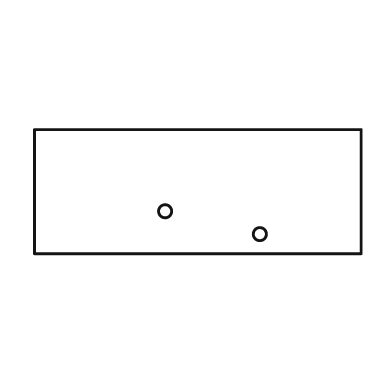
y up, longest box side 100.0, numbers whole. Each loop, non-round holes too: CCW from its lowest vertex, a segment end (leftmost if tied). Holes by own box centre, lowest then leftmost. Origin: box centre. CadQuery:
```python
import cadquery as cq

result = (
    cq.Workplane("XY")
    .moveTo(-50.0, -19.0)
    .lineTo(50.0, -19.0)
    .lineTo(50.0, 19.0)
    .lineTo(-50.0, 19.0)
    .close()
    .moveTo(19.0, -13.0)
    .circle(2.0)
    .moveTo(-10.0, -6.0)
    .circle(2.0)
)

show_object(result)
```